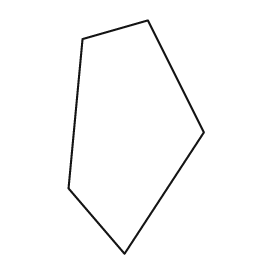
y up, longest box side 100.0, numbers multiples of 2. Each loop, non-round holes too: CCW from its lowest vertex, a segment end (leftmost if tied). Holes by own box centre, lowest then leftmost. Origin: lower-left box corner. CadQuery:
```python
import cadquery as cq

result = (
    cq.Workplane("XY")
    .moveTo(24.0, 0.0)
    .lineTo(58.0, 52.0)
    .lineTo(34.0, 100.0)
    .lineTo(6.0, 92.0)
    .lineTo(0.0, 28.0)
    .close()
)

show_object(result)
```